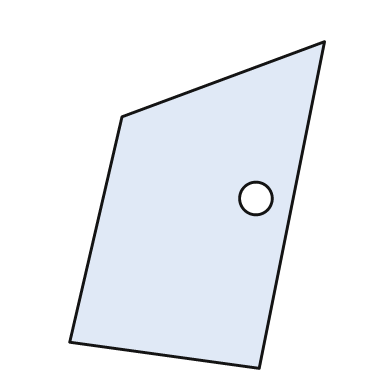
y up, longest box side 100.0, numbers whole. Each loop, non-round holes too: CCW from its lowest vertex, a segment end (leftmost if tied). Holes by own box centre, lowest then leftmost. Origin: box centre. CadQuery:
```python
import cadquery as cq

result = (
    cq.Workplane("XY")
    .moveTo(19.0, -50.0)
    .lineTo(39.0, 50.0)
    .lineTo(-23.0, 27.0)
    .lineTo(-39.0, -42.0)
    .close()
    .moveTo(18.0, 2.0)
    .circle(5.0)
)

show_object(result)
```